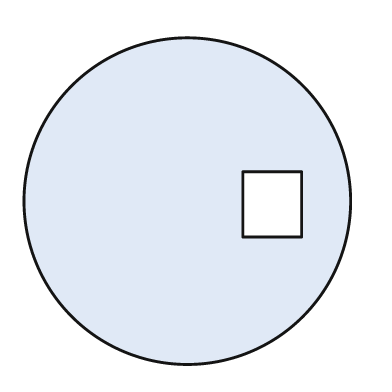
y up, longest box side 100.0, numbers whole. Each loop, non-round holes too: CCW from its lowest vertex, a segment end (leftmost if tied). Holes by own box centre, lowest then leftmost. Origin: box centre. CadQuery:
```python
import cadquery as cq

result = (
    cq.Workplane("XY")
    .moveTo(0.0, 0.0)
    .circle(50.0)
    .moveTo(17.0, -11.0)
    .lineTo(35.0, -11.0)
    .lineTo(35.0, 9.0)
    .lineTo(17.0, 9.0)
    .close()
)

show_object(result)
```